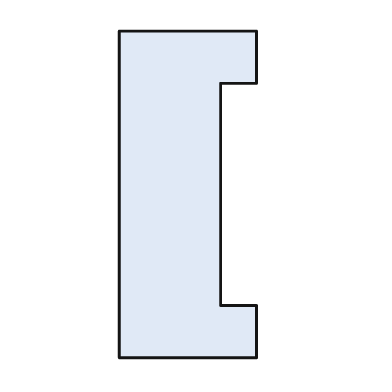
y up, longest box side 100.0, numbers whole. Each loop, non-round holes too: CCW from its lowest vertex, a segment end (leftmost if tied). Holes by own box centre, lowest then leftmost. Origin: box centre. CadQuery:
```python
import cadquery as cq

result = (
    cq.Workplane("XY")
    .moveTo(-21.0, -50.0)
    .lineTo(21.0, -50.0)
    .lineTo(21.0, -34.0)
    .lineTo(10.0, -34.0)
    .lineTo(10.0, 34.0)
    .lineTo(21.0, 34.0)
    .lineTo(21.0, 50.0)
    .lineTo(-21.0, 50.0)
    .close()
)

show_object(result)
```